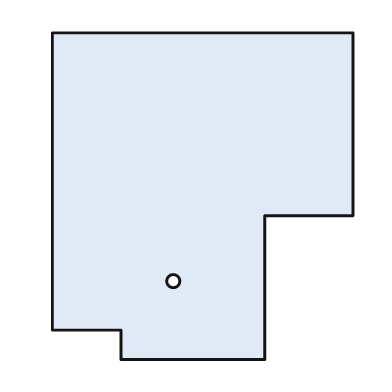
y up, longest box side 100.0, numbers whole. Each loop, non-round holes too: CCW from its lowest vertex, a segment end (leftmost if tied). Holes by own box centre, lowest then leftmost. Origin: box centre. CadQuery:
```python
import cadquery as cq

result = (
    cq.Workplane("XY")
    .moveTo(-25.0, -50.0)
    .lineTo(19.0, -50.0)
    .lineTo(19.0, -6.0)
    .lineTo(46.0, -6.0)
    .lineTo(46.0, 50.0)
    .lineTo(-46.0, 50.0)
    .lineTo(-46.0, -41.0)
    .lineTo(-25.0, -41.0)
    .close()
    .moveTo(-9.0, -26.0)
    .circle(2.0)
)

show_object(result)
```